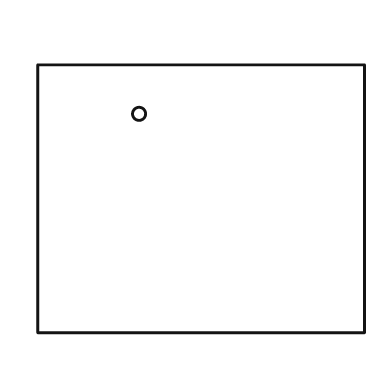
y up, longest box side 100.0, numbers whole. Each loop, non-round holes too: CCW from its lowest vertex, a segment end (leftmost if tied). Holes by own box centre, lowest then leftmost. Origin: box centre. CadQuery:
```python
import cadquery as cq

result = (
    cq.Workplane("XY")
    .moveTo(-50.0, -41.0)
    .lineTo(50.0, -41.0)
    .lineTo(50.0, 41.0)
    .lineTo(-50.0, 41.0)
    .close()
    .moveTo(-19.0, 26.0)
    .circle(2.0)
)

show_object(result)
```